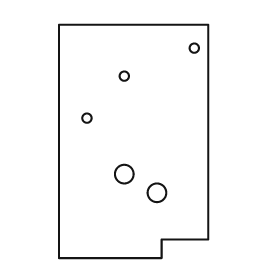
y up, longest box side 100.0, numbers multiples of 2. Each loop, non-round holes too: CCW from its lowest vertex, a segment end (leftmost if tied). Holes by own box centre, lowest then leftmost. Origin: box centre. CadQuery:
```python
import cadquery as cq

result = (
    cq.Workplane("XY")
    .moveTo(-32.0, -50.0)
    .lineTo(12.0, -50.0)
    .lineTo(12.0, -42.0)
    .lineTo(32.0, -42.0)
    .lineTo(32.0, 50.0)
    .lineTo(-32.0, 50.0)
    .close()
    .moveTo(10.0, -22.0)
    .circle(4.0)
    .moveTo(-4.0, -14.0)
    .circle(4.0)
    .moveTo(-20.0, 10.0)
    .circle(2.0)
    .moveTo(-4.0, 28.0)
    .circle(2.0)
    .moveTo(26.0, 40.0)
    .circle(2.0)
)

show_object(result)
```